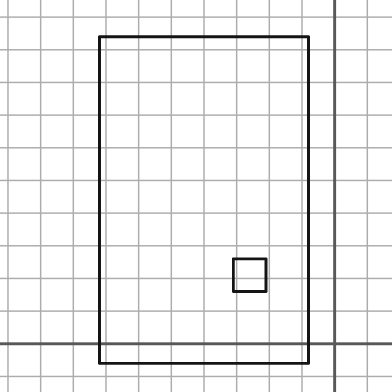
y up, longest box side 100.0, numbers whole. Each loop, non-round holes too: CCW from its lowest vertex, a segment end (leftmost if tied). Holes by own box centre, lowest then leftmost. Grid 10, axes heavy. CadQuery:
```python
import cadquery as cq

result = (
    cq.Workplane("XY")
    .moveTo(-72.0, -6.0)
    .lineTo(-8.0, -6.0)
    .lineTo(-8.0, 94.0)
    .lineTo(-72.0, 94.0)
    .close()
    .moveTo(-31.0, 16.0)
    .lineTo(-21.0, 16.0)
    .lineTo(-21.0, 26.0)
    .lineTo(-31.0, 26.0)
    .close()
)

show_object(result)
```